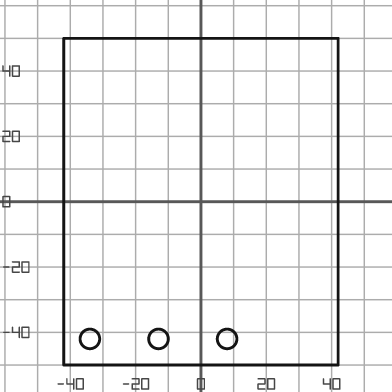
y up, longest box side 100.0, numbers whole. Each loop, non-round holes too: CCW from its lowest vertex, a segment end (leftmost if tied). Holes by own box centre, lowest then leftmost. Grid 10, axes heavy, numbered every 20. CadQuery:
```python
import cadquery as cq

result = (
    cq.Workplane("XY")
    .moveTo(-42.0, -50.0)
    .lineTo(42.0, -50.0)
    .lineTo(42.0, 50.0)
    .lineTo(-42.0, 50.0)
    .close()
    .moveTo(-34.0, -42.0)
    .circle(3.0)
    .moveTo(-13.0, -42.0)
    .circle(3.0)
    .moveTo(8.0, -42.0)
    .circle(3.0)
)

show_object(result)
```